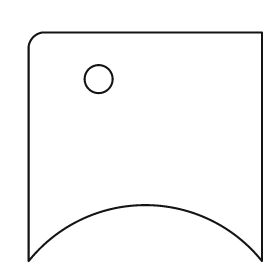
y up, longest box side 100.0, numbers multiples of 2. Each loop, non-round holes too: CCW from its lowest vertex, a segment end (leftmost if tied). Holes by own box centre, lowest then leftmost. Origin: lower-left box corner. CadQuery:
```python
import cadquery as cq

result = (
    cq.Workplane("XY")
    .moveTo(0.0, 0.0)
    .threePointArc((50.0, 24.0), (100.0, 0.0))
    .lineTo(100.0, 98.0)
    .lineTo(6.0, 98.0)
    .threePointArc((2.0, 96.0), (0.0, 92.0))
    .close()
    .moveTo(30.0, 78.0)
    .circle(6.0)
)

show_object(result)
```